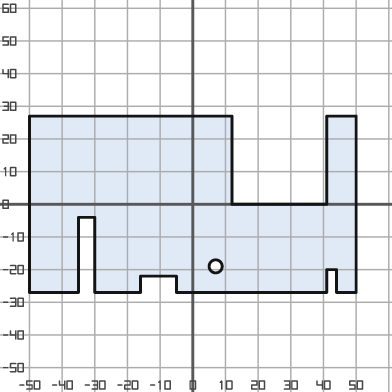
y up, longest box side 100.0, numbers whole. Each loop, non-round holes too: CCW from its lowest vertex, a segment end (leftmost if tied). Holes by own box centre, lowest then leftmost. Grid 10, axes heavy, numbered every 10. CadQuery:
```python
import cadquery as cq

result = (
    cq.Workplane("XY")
    .moveTo(-50.0, -27.0)
    .lineTo(-35.0, -27.0)
    .lineTo(-35.0, -4.0)
    .lineTo(-30.0, -4.0)
    .lineTo(-30.0, -27.0)
    .lineTo(-16.0, -27.0)
    .lineTo(-16.0, -22.0)
    .lineTo(-5.0, -22.0)
    .lineTo(-5.0, -27.0)
    .lineTo(41.0, -27.0)
    .lineTo(41.0, -20.0)
    .lineTo(44.0, -20.0)
    .lineTo(44.0, -27.0)
    .lineTo(50.0, -27.0)
    .lineTo(50.0, 27.0)
    .lineTo(41.0, 27.0)
    .lineTo(41.0, 0.0)
    .lineTo(12.0, 0.0)
    .lineTo(12.0, 27.0)
    .lineTo(-50.0, 27.0)
    .close()
    .moveTo(7.0, -19.0)
    .circle(2.0)
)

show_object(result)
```